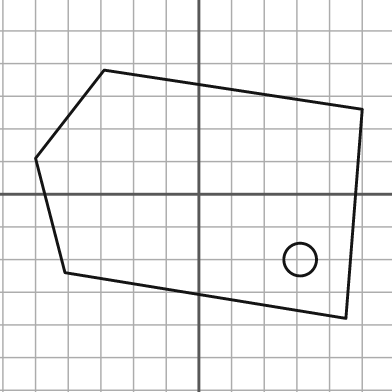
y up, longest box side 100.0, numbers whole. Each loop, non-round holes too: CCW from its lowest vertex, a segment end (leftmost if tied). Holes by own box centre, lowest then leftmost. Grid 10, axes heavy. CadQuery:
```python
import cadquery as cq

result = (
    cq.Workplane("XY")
    .moveTo(45.0, -38.0)
    .lineTo(50.0, 26.0)
    .lineTo(-29.0, 38.0)
    .lineTo(-50.0, 11.0)
    .lineTo(-41.0, -24.0)
    .close()
    .moveTo(31.0, -20.0)
    .circle(5.0)
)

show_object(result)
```